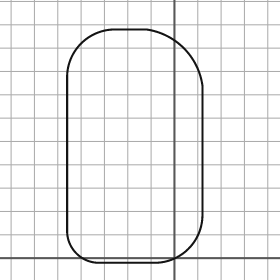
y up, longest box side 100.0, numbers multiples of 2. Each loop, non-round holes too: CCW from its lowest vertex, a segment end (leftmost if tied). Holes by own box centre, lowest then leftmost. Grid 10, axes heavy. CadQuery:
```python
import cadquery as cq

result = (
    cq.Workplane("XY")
    .moveTo(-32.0, -2.0)
    .lineTo(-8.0, -2.0)
    .threePointArc((6.0, 4.0), (12.0, 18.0))
    .lineTo(12.0, 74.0)
    .threePointArc((4.0, 90.0), (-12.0, 98.0))
    .lineTo(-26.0, 98.0)
    .threePointArc((-40.0, 92.0), (-46.0, 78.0))
    .lineTo(-46.0, 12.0)
    .threePointArc((-42.0, 2.0), (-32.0, -2.0))
    .close()
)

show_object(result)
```